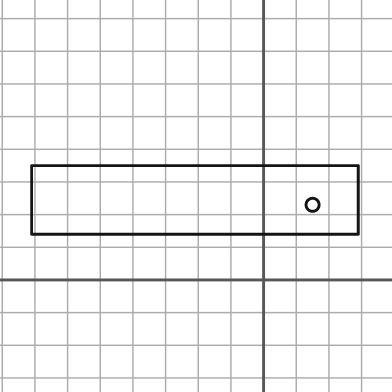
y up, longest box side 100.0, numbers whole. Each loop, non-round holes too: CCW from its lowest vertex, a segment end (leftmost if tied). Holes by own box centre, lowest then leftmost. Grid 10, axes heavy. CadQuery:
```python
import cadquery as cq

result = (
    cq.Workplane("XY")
    .moveTo(-71.0, 14.0)
    .lineTo(29.0, 14.0)
    .lineTo(29.0, 35.0)
    .lineTo(-71.0, 35.0)
    .close()
    .moveTo(15.0, 23.0)
    .circle(2.0)
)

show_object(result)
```